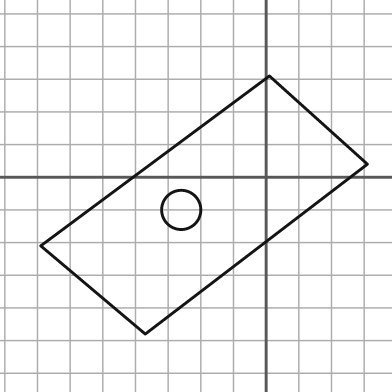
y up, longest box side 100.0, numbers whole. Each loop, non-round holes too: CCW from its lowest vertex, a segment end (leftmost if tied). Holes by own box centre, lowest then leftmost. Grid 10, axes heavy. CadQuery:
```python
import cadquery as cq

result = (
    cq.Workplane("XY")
    .moveTo(-37.0, -48.0)
    .lineTo(31.0, 4.0)
    .lineTo(1.0, 31.0)
    .lineTo(-69.0, -21.0)
    .close()
    .moveTo(-26.0, -10.0)
    .circle(6.0)
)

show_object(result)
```